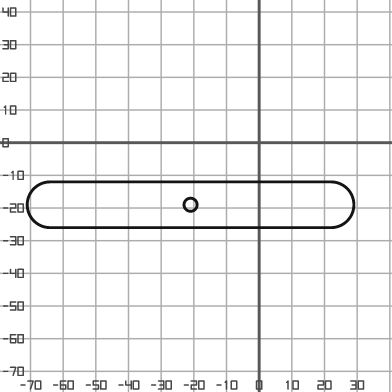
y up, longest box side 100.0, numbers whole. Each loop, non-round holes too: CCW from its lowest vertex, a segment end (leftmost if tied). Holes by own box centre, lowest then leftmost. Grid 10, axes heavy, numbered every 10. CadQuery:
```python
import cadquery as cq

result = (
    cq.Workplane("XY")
    .moveTo(-64.0, -26.0)
    .lineTo(22.0, -26.0)
    .threePointArc((29.0, -19.0), (22.0, -12.0))
    .lineTo(-64.0, -12.0)
    .threePointArc((-71.0, -19.0), (-64.0, -26.0))
    .close()
    .moveTo(-21.0, -19.0)
    .circle(2.0)
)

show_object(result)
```